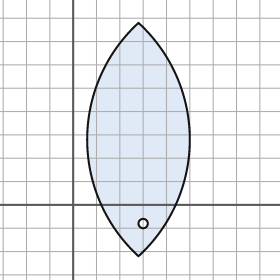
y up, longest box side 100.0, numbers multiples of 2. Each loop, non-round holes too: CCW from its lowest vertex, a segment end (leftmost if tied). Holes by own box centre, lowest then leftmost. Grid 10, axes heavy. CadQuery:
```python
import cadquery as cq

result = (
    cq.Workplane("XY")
    .moveTo(28.0, -22.0)
    .threePointArc((50.0, 28.0), (28.0, 78.0))
    .threePointArc((6.0, 28.0), (28.0, -22.0))
    .close()
    .moveTo(30.0, -8.0)
    .circle(2.0)
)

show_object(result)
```